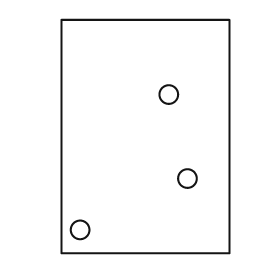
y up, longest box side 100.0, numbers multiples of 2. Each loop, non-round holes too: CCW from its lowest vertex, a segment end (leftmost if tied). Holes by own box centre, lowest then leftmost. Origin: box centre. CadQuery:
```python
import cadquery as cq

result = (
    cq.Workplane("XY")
    .moveTo(-36.0, -50.0)
    .lineTo(36.0, -50.0)
    .lineTo(36.0, 50.0)
    .lineTo(-36.0, 50.0)
    .close()
    .moveTo(-28.0, -40.0)
    .circle(4.0)
    .moveTo(18.0, -18.0)
    .circle(4.0)
    .moveTo(10.0, 18.0)
    .circle(4.0)
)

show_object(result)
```